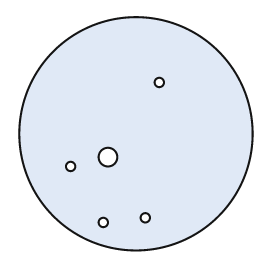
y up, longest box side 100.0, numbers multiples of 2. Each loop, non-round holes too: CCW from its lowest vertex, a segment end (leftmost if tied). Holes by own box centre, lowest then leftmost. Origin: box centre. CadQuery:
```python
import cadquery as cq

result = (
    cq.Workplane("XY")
    .moveTo(0.0, 0.0)
    .circle(50.0)
    .moveTo(-14.0, -38.0)
    .circle(2.0)
    .moveTo(4.0, -36.0)
    .circle(2.0)
    .moveTo(-28.0, -14.0)
    .circle(2.0)
    .moveTo(-12.0, -10.0)
    .circle(4.0)
    .moveTo(10.0, 22.0)
    .circle(2.0)
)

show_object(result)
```